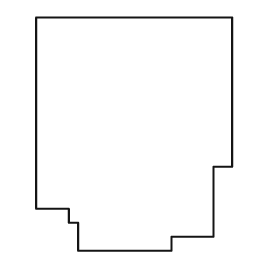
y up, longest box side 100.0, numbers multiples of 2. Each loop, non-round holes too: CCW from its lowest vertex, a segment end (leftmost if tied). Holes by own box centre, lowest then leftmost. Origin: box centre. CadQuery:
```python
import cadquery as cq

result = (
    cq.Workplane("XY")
    .moveTo(-24.0, -50.0)
    .lineTo(16.0, -50.0)
    .lineTo(16.0, -44.0)
    .lineTo(34.0, -44.0)
    .lineTo(34.0, -14.0)
    .lineTo(42.0, -14.0)
    .lineTo(42.0, 50.0)
    .lineTo(-42.0, 50.0)
    .lineTo(-42.0, -32.0)
    .lineTo(-28.0, -32.0)
    .lineTo(-28.0, -38.0)
    .lineTo(-24.0, -38.0)
    .close()
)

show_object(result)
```